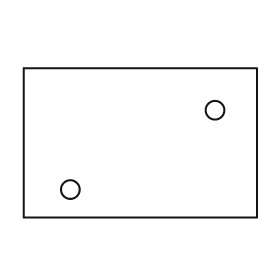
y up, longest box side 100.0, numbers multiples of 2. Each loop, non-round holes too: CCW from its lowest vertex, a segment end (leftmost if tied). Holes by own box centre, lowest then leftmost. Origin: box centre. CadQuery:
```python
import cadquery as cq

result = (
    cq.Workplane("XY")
    .moveTo(-50.0, -32.0)
    .lineTo(50.0, -32.0)
    .lineTo(50.0, 32.0)
    .lineTo(-50.0, 32.0)
    .close()
    .moveTo(-30.0, -20.0)
    .circle(4.0)
    .moveTo(32.0, 14.0)
    .circle(4.0)
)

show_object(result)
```